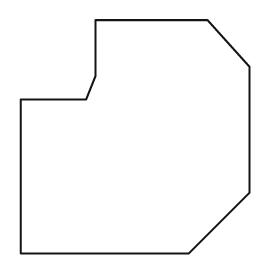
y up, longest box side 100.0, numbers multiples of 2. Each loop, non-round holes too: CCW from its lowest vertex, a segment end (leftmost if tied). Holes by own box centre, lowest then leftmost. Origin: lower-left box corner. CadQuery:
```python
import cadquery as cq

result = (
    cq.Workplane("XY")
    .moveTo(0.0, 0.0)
    .lineTo(72.0, 0.0)
    .lineTo(98.0, 26.0)
    .lineTo(98.0, 80.0)
    .lineTo(80.0, 100.0)
    .lineTo(32.0, 100.0)
    .lineTo(32.0, 76.0)
    .lineTo(28.0, 66.0)
    .lineTo(0.0, 66.0)
    .close()
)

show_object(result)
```